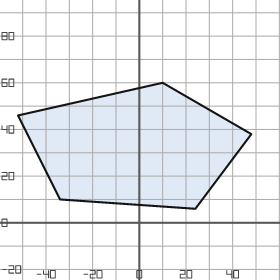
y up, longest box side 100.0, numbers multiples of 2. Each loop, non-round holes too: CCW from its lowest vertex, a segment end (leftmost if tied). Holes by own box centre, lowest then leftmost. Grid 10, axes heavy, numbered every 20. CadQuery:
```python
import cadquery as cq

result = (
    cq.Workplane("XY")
    .moveTo(24.0, 6.0)
    .lineTo(48.0, 38.0)
    .lineTo(10.0, 60.0)
    .lineTo(-52.0, 46.0)
    .lineTo(-34.0, 10.0)
    .close()
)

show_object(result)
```